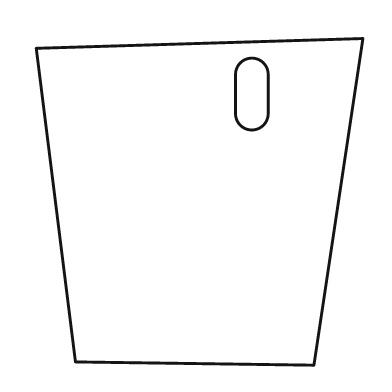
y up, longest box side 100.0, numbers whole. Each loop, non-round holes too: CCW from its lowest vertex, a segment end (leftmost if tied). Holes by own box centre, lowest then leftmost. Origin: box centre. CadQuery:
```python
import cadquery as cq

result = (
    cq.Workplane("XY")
    .moveTo(35.0, -50.0)
    .lineTo(50.0, 50.0)
    .lineTo(-50.0, 47.0)
    .lineTo(-38.0, -49.0)
    .close()
    .moveTo(11.0, 27.0)
    .threePointArc((16.0, 22.0), (21.0, 27.0))
    .lineTo(21.0, 39.0)
    .threePointArc((16.0, 44.0), (11.0, 39.0))
    .close()
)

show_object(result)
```